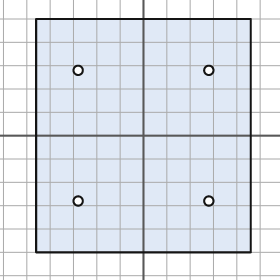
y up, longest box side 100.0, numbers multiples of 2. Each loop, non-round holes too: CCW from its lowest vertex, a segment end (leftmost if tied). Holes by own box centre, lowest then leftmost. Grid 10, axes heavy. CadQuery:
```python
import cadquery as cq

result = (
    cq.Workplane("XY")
    .moveTo(-46.0, -50.0)
    .lineTo(46.0, -50.0)
    .lineTo(46.0, 50.0)
    .lineTo(-46.0, 50.0)
    .close()
    .moveTo(-28.0, -28.0)
    .circle(2.0)
    .moveTo(28.0, -28.0)
    .circle(2.0)
    .moveTo(-28.0, 28.0)
    .circle(2.0)
    .moveTo(28.0, 28.0)
    .circle(2.0)
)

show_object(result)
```